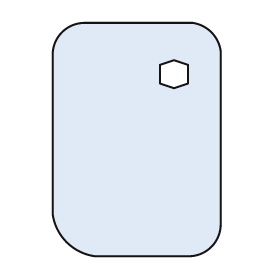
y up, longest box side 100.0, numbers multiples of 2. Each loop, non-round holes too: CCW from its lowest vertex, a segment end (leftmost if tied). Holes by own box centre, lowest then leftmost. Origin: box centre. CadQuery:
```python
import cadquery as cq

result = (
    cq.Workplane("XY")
    .moveTo(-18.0, -50.0)
    .lineTo(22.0, -50.0)
    .threePointArc((32.0, -46.0), (36.0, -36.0))
    .lineTo(36.0, 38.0)
    .threePointArc((32.0, 46.0), (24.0, 50.0))
    .lineTo(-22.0, 50.0)
    .threePointArc((-32.0, 46.0), (-36.0, 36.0))
    .lineTo(-36.0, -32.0)
    .threePointArc((-30.0, -44.0), (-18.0, -50.0))
    .close()
    .moveTo(16.0, 22.0)
    .lineTo(22.0, 24.0)
    .lineTo(22.0, 32.0)
    .lineTo(16.0, 34.0)
    .lineTo(10.0, 32.0)
    .lineTo(10.0, 24.0)
    .close()
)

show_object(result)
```